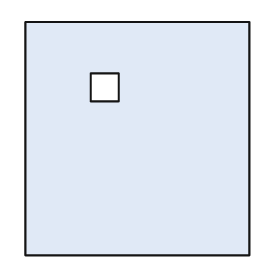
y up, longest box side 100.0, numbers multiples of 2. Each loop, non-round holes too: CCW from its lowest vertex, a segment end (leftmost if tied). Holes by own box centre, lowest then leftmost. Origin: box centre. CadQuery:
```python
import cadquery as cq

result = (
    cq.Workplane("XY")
    .moveTo(-48.0, -50.0)
    .lineTo(48.0, -50.0)
    .lineTo(48.0, 50.0)
    .lineTo(-48.0, 50.0)
    .close()
    .moveTo(-20.0, 16.0)
    .lineTo(-8.0, 16.0)
    .lineTo(-8.0, 28.0)
    .lineTo(-20.0, 28.0)
    .close()
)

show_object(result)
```